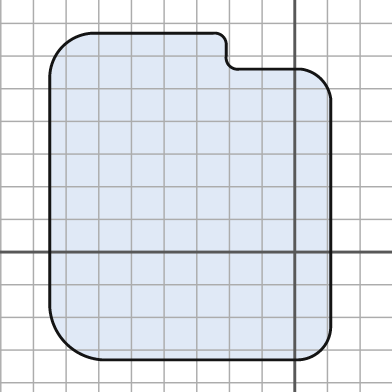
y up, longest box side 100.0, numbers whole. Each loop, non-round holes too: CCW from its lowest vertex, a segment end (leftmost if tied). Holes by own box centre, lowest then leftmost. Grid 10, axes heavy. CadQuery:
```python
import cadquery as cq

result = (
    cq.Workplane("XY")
    .moveTo(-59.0, -33.0)
    .lineTo(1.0, -33.0)
    .threePointArc((8.0, -30.0), (11.0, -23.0))
    .lineTo(11.0, 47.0)
    .threePointArc((8.0, 53.0), (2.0, 56.0))
    .lineTo(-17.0, 56.0)
    .threePointArc((-20.0, 57.0), (-21.0, 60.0))
    .lineTo(-21.0, 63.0)
    .threePointArc((-22.0, 66.0), (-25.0, 67.0))
    .lineTo(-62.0, 67.0)
    .threePointArc((-71.0, 63.0), (-75.0, 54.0))
    .lineTo(-75.0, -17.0)
    .threePointArc((-70.0, -28.0), (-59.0, -33.0))
    .close()
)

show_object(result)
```